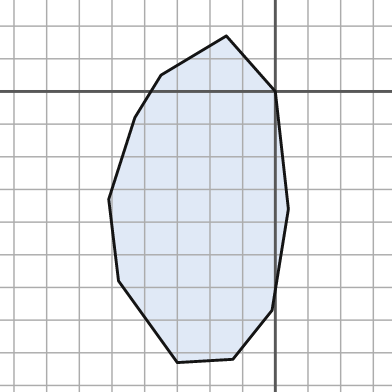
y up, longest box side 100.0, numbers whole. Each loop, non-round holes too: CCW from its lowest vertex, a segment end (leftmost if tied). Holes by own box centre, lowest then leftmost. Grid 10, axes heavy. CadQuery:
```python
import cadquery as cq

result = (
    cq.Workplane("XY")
    .moveTo(-30.0, -83.0)
    .lineTo(-13.0, -82.0)
    .lineTo(-1.0, -67.0)
    .lineTo(4.0, -36.0)
    .lineTo(0.0, 0.0)
    .lineTo(-15.0, 17.0)
    .lineTo(-35.0, 5.0)
    .lineTo(-43.0, -8.0)
    .lineTo(-51.0, -33.0)
    .lineTo(-48.0, -58.0)
    .close()
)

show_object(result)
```